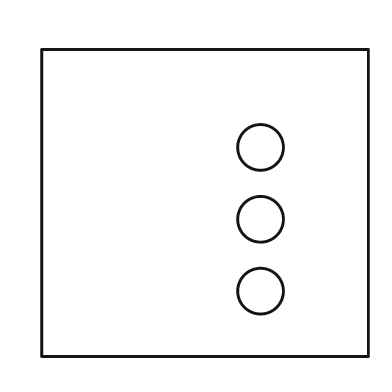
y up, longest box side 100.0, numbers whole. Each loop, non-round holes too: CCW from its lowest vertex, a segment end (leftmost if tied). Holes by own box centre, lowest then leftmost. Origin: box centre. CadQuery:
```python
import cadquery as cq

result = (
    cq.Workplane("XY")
    .moveTo(-50.0, -47.0)
    .lineTo(50.0, -47.0)
    .lineTo(50.0, 47.0)
    .lineTo(-50.0, 47.0)
    .close()
    .moveTo(17.0, -27.0)
    .circle(7.0)
    .moveTo(17.0, -5.0)
    .circle(7.0)
    .moveTo(17.0, 17.0)
    .circle(7.0)
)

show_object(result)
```